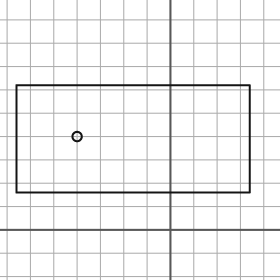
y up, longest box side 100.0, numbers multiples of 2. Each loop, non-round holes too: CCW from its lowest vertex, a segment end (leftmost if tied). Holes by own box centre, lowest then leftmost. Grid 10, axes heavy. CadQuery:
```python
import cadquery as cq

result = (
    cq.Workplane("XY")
    .moveTo(-66.0, 16.0)
    .lineTo(34.0, 16.0)
    .lineTo(34.0, 62.0)
    .lineTo(-66.0, 62.0)
    .close()
    .moveTo(-40.0, 40.0)
    .circle(2.0)
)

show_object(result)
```